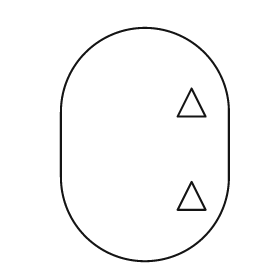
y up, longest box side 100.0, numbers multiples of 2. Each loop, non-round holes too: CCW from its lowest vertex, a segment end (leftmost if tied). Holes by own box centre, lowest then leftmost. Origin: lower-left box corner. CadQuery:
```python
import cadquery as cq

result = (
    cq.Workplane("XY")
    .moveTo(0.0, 36.0)
    .threePointArc((36.0, 0.0), (72.0, 36.0))
    .lineTo(72.0, 64.0)
    .threePointArc((36.0, 100.0), (0.0, 64.0))
    .close()
    .moveTo(50.0, 22.0)
    .lineTo(62.0, 22.0)
    .lineTo(56.0, 34.0)
    .close()
    .moveTo(50.0, 62.0)
    .lineTo(62.0, 62.0)
    .lineTo(56.0, 74.0)
    .close()
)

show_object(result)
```